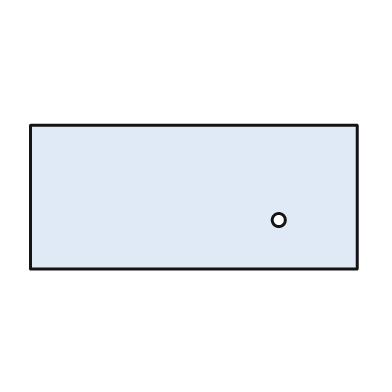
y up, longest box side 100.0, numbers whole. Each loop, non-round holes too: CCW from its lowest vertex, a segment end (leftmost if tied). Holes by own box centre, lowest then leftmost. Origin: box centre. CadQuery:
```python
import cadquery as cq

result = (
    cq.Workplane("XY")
    .moveTo(-50.0, -22.0)
    .lineTo(50.0, -22.0)
    .lineTo(50.0, 22.0)
    .lineTo(-50.0, 22.0)
    .close()
    .moveTo(26.0, -7.0)
    .circle(2.0)
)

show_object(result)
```